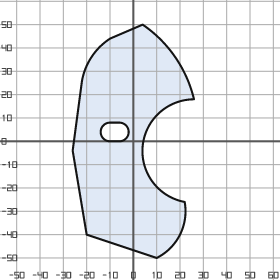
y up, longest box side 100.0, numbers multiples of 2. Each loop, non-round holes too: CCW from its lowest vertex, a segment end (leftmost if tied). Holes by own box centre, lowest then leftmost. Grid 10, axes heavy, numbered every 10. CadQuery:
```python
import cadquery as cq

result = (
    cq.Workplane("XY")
    .moveTo(10.0, -50.0)
    .threePointArc((20.0, -40.0), (22.0, -26.0))
    .threePointArc((4.0, -2.0), (26.0, 18.0))
    .threePointArc((18.0, 36.0), (4.0, 50.0))
    .lineTo(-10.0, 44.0)
    .threePointArc((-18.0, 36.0), (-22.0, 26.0))
    .lineTo(-26.0, -4.0)
    .lineTo(-20.0, -40.0)
    .close()
    .moveTo(-10.0, 0.0)
    .lineTo(-6.0, 0.0)
    .threePointArc((-2.0, 4.0), (-6.0, 8.0))
    .lineTo(-10.0, 8.0)
    .threePointArc((-14.0, 4.0), (-10.0, 0.0))
    .close()
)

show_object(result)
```